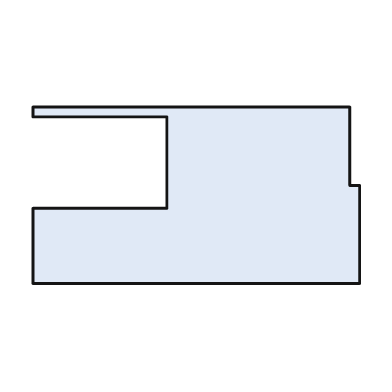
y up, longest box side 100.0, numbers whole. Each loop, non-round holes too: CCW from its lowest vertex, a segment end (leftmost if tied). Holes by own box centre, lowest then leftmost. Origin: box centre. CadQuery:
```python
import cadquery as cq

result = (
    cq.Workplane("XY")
    .moveTo(-50.0, -27.0)
    .lineTo(50.0, -27.0)
    .lineTo(50.0, 3.0)
    .lineTo(47.0, 3.0)
    .lineTo(47.0, 27.0)
    .lineTo(-50.0, 27.0)
    .lineTo(-50.0, 24.0)
    .lineTo(-9.0, 24.0)
    .lineTo(-9.0, -4.0)
    .lineTo(-50.0, -4.0)
    .close()
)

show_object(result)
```